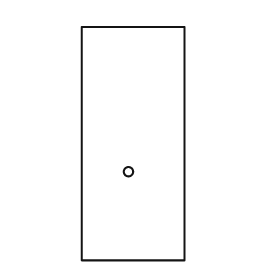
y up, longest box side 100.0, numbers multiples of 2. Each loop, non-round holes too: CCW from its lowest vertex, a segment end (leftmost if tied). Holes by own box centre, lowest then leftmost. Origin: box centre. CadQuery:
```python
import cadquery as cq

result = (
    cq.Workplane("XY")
    .moveTo(-22.0, -50.0)
    .lineTo(22.0, -50.0)
    .lineTo(22.0, 50.0)
    .lineTo(-22.0, 50.0)
    .close()
    .moveTo(-2.0, -12.0)
    .circle(2.0)
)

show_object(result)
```